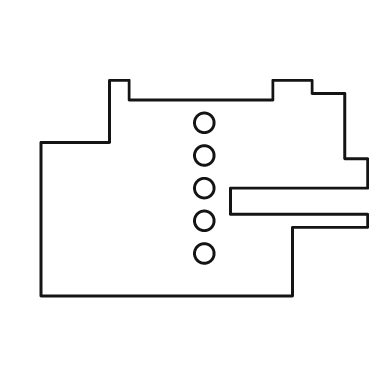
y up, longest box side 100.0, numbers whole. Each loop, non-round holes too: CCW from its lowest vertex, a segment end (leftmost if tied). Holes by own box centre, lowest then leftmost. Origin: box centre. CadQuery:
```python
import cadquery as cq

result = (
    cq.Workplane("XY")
    .moveTo(-50.0, -33.0)
    .lineTo(27.0, -33.0)
    .lineTo(27.0, -12.0)
    .lineTo(50.0, -12.0)
    .lineTo(50.0, -8.0)
    .lineTo(8.0, -8.0)
    .lineTo(8.0, 0.0)
    .lineTo(50.0, 0.0)
    .lineTo(50.0, 9.0)
    .lineTo(43.0, 9.0)
    .lineTo(43.0, 29.0)
    .lineTo(33.0, 29.0)
    .lineTo(33.0, 33.0)
    .lineTo(21.0, 33.0)
    .lineTo(21.0, 27.0)
    .lineTo(-23.0, 27.0)
    .lineTo(-23.0, 33.0)
    .lineTo(-29.0, 33.0)
    .lineTo(-29.0, 14.0)
    .lineTo(-50.0, 14.0)
    .close()
    .moveTo(0.0, -20.0)
    .circle(3.0)
    .moveTo(0.0, -10.0)
    .circle(3.0)
    .moveTo(0.0, 0.0)
    .circle(3.0)
    .moveTo(0.0, 10.0)
    .circle(3.0)
    .moveTo(0.0, 20.0)
    .circle(3.0)
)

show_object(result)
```